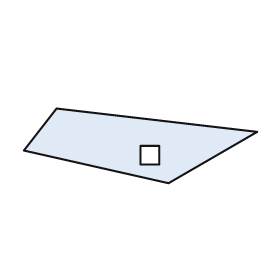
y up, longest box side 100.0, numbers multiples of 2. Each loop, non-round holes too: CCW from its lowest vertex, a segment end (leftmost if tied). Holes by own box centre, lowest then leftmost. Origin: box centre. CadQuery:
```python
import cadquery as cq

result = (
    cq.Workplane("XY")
    .moveTo(12.0, -16.0)
    .lineTo(50.0, 6.0)
    .lineTo(-36.0, 16.0)
    .lineTo(-50.0, -2.0)
    .close()
    .moveTo(0.0, -8.0)
    .lineTo(8.0, -8.0)
    .lineTo(8.0, 0.0)
    .lineTo(0.0, 0.0)
    .close()
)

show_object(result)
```